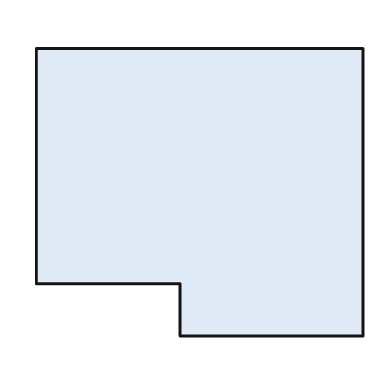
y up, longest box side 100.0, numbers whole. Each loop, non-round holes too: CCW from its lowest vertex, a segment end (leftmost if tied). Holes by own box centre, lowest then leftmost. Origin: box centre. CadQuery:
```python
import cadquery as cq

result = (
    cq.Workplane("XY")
    .moveTo(-6.0, -44.0)
    .lineTo(50.0, -44.0)
    .lineTo(50.0, 44.0)
    .lineTo(-50.0, 44.0)
    .lineTo(-50.0, -28.0)
    .lineTo(-6.0, -28.0)
    .close()
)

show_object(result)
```